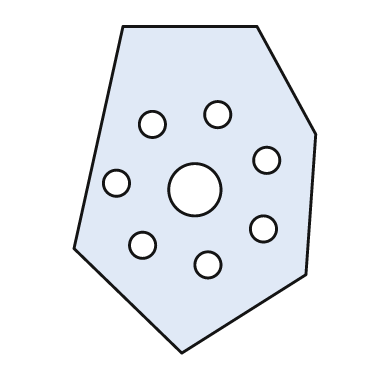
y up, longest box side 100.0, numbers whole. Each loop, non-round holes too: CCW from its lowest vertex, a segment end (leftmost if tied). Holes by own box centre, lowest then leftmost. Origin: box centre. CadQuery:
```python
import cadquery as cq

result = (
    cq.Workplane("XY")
    .moveTo(-4.0, -50.0)
    .lineTo(34.0, -26.0)
    .lineTo(37.0, 17.0)
    .lineTo(19.0, 50.0)
    .lineTo(-22.0, 50.0)
    .lineTo(-37.0, -18.0)
    .close()
    .moveTo(4.0, -23.0)
    .circle(4.0)
    .moveTo(-16.0, -17.0)
    .circle(4.0)
    .moveTo(21.0, -12.0)
    .circle(4.0)
    .moveTo(0.0, 0.0)
    .circle(8.0)
    .moveTo(-24.0, 2.0)
    .circle(4.0)
    .moveTo(22.0, 9.0)
    .circle(4.0)
    .moveTo(-13.0, 20.0)
    .circle(4.0)
    .moveTo(7.0, 23.0)
    .circle(4.0)
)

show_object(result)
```